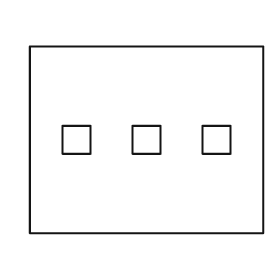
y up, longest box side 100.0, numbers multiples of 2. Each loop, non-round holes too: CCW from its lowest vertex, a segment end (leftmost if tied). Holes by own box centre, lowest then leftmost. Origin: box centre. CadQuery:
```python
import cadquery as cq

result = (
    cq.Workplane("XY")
    .moveTo(-50.0, -40.0)
    .lineTo(50.0, -40.0)
    .lineTo(50.0, 40.0)
    .lineTo(-50.0, 40.0)
    .close()
    .moveTo(-36.0, -6.0)
    .lineTo(-24.0, -6.0)
    .lineTo(-24.0, 6.0)
    .lineTo(-36.0, 6.0)
    .close()
    .moveTo(-6.0, -6.0)
    .lineTo(6.0, -6.0)
    .lineTo(6.0, 6.0)
    .lineTo(-6.0, 6.0)
    .close()
    .moveTo(24.0, -6.0)
    .lineTo(36.0, -6.0)
    .lineTo(36.0, 6.0)
    .lineTo(24.0, 6.0)
    .close()
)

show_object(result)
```